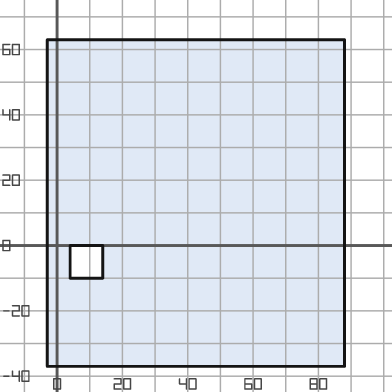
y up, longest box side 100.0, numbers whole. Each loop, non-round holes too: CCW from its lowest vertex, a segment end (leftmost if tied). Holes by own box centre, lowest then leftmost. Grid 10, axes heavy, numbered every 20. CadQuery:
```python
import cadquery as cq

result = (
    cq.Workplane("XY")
    .moveTo(-3.0, -37.0)
    .lineTo(88.0, -37.0)
    .lineTo(88.0, 63.0)
    .lineTo(-3.0, 63.0)
    .close()
    .moveTo(4.0, -10.0)
    .lineTo(14.0, -10.0)
    .lineTo(14.0, 0.0)
    .lineTo(4.0, 0.0)
    .close()
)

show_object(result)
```